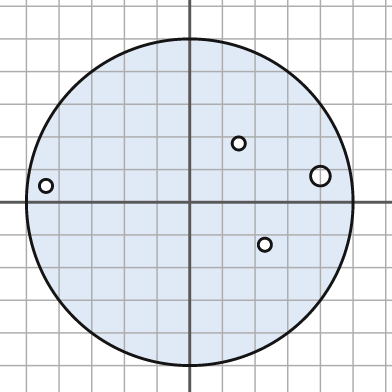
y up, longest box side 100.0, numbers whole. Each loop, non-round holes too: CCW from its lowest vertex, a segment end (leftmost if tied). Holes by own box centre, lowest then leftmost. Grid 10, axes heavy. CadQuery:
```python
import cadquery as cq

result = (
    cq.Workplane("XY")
    .moveTo(0.0, 0.0)
    .circle(50.0)
    .moveTo(23.0, -13.0)
    .circle(2.0)
    .moveTo(-44.0, 5.0)
    .circle(2.0)
    .moveTo(40.0, 8.0)
    .circle(3.0)
    .moveTo(15.0, 18.0)
    .circle(2.0)
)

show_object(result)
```